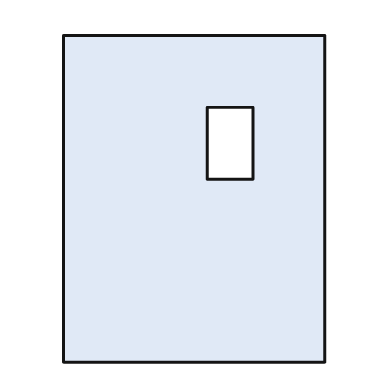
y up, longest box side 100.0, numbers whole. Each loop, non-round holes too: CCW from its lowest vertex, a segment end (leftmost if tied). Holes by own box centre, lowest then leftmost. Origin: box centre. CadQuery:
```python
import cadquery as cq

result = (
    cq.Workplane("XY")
    .moveTo(-40.0, -50.0)
    .lineTo(40.0, -50.0)
    .lineTo(40.0, 50.0)
    .lineTo(-40.0, 50.0)
    .close()
    .moveTo(4.0, 6.0)
    .lineTo(18.0, 6.0)
    .lineTo(18.0, 28.0)
    .lineTo(4.0, 28.0)
    .close()
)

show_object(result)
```